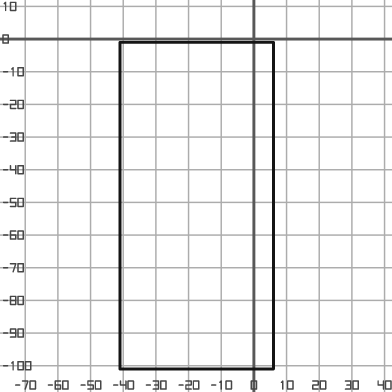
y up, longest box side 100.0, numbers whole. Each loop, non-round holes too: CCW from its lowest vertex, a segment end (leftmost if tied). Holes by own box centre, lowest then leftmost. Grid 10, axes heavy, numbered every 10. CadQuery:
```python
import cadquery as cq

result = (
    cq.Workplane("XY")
    .moveTo(-41.0, -101.0)
    .lineTo(6.0, -101.0)
    .lineTo(6.0, -1.0)
    .lineTo(-41.0, -1.0)
    .close()
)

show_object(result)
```